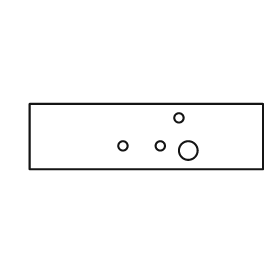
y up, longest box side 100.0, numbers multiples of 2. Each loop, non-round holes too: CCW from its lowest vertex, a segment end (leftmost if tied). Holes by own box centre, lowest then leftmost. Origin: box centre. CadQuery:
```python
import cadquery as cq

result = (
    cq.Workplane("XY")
    .moveTo(-50.0, -14.0)
    .lineTo(50.0, -14.0)
    .lineTo(50.0, 14.0)
    .lineTo(-50.0, 14.0)
    .close()
    .moveTo(18.0, -6.0)
    .circle(4.0)
    .moveTo(-10.0, -4.0)
    .circle(2.0)
    .moveTo(6.0, -4.0)
    .circle(2.0)
    .moveTo(14.0, 8.0)
    .circle(2.0)
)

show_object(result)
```